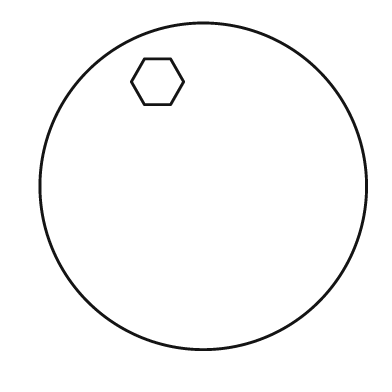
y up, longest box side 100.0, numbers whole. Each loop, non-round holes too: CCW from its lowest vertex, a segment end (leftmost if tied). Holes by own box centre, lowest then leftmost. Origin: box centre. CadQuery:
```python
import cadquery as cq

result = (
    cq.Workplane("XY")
    .moveTo(0.0, 0.0)
    .circle(50.0)
    .moveTo(-18.0, 25.0)
    .lineTo(-10.0, 25.0)
    .lineTo(-6.0, 32.0)
    .lineTo(-10.0, 39.0)
    .lineTo(-18.0, 39.0)
    .lineTo(-22.0, 32.0)
    .close()
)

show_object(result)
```